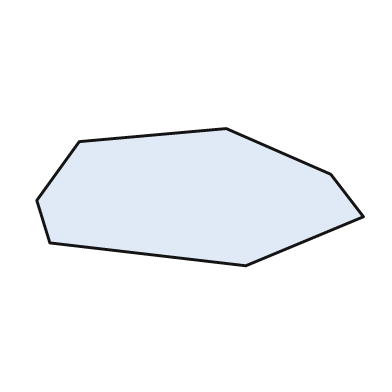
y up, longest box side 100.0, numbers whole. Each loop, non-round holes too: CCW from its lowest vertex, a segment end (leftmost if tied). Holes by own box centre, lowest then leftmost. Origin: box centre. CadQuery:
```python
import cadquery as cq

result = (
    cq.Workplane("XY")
    .moveTo(14.0, -21.0)
    .lineTo(50.0, -6.0)
    .lineTo(40.0, 7.0)
    .lineTo(8.0, 21.0)
    .lineTo(-37.0, 17.0)
    .lineTo(-50.0, -1.0)
    .lineTo(-46.0, -14.0)
    .close()
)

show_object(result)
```